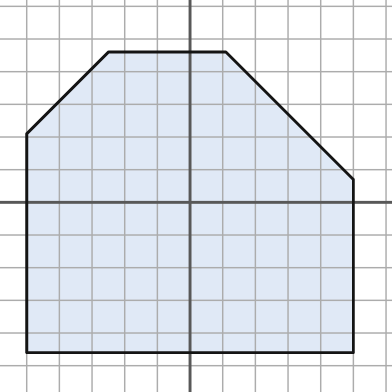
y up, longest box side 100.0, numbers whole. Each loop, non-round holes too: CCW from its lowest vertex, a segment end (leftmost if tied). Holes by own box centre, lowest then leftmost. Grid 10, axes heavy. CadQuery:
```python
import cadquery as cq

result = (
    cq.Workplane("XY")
    .moveTo(-50.0, -46.0)
    .lineTo(50.0, -46.0)
    .lineTo(50.0, 7.0)
    .lineTo(11.0, 46.0)
    .lineTo(-25.0, 46.0)
    .lineTo(-50.0, 21.0)
    .close()
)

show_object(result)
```